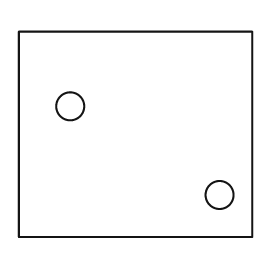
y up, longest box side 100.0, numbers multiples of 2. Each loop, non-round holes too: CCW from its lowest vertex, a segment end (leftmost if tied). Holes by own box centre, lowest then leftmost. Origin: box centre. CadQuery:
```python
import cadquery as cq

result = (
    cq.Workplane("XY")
    .moveTo(-50.0, -44.0)
    .lineTo(50.0, -44.0)
    .lineTo(50.0, 44.0)
    .lineTo(-50.0, 44.0)
    .close()
    .moveTo(36.0, -26.0)
    .circle(6.0)
    .moveTo(-28.0, 12.0)
    .circle(6.0)
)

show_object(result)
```